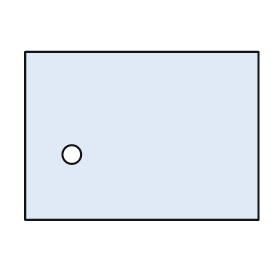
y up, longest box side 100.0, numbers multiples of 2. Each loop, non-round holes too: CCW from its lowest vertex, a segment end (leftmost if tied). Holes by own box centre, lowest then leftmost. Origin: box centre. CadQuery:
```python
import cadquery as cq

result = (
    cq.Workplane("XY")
    .moveTo(-50.0, -36.0)
    .lineTo(50.0, -36.0)
    .lineTo(50.0, 36.0)
    .lineTo(-50.0, 36.0)
    .close()
    .moveTo(-30.0, -8.0)
    .circle(4.0)
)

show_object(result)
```